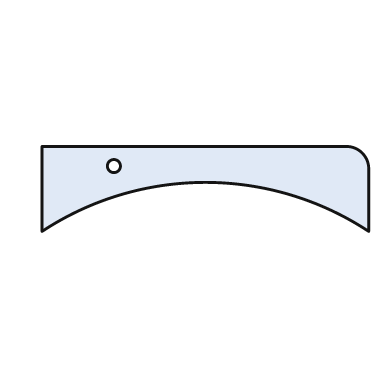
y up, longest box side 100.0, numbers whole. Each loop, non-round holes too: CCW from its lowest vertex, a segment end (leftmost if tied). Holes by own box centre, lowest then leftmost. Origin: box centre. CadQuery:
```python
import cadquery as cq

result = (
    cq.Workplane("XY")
    .moveTo(-50.0, -13.0)
    .threePointArc((0.0, 2.0), (50.0, -13.0))
    .lineTo(50.0, 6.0)
    .threePointArc((48.0, 11.0), (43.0, 13.0))
    .lineTo(-50.0, 13.0)
    .close()
    .moveTo(-28.0, 7.0)
    .circle(2.0)
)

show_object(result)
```